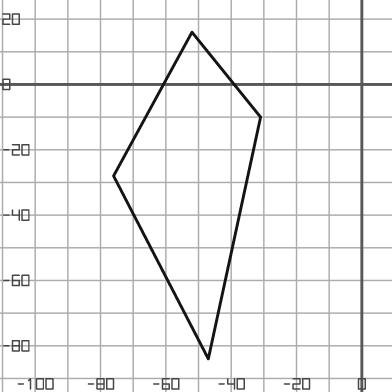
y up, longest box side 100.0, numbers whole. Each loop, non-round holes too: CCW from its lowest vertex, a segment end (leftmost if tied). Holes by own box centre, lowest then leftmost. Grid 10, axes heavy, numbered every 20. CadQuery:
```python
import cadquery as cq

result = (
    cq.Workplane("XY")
    .moveTo(-47.0, -84.0)
    .lineTo(-31.0, -10.0)
    .lineTo(-52.0, 16.0)
    .lineTo(-76.0, -28.0)
    .close()
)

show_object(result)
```